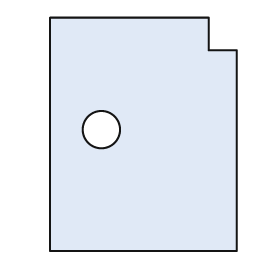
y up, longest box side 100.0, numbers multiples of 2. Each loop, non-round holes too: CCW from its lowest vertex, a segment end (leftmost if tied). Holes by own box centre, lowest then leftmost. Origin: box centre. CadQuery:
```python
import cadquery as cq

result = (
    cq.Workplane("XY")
    .moveTo(-40.0, -50.0)
    .lineTo(40.0, -50.0)
    .lineTo(40.0, 36.0)
    .lineTo(28.0, 36.0)
    .lineTo(28.0, 50.0)
    .lineTo(-40.0, 50.0)
    .close()
    .moveTo(-18.0, 2.0)
    .circle(8.0)
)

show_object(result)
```